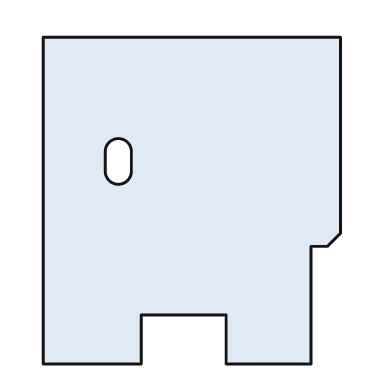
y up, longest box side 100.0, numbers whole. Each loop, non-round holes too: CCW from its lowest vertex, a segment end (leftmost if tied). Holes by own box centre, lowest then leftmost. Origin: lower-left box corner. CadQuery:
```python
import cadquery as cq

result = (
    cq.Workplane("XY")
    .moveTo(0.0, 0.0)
    .lineTo(30.0, 0.0)
    .lineTo(30.0, 15.0)
    .lineTo(56.0, 15.0)
    .lineTo(56.0, 0.0)
    .lineTo(82.0, 0.0)
    .lineTo(82.0, 36.0)
    .lineTo(87.0, 36.0)
    .lineTo(91.0, 40.0)
    .lineTo(91.0, 100.0)
    .lineTo(0.0, 100.0)
    .close()
    .moveTo(19.0, 59.0)
    .threePointArc((23.0, 55.0), (27.0, 59.0))
    .lineTo(27.0, 65.0)
    .threePointArc((23.0, 69.0), (19.0, 65.0))
    .close()
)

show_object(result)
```